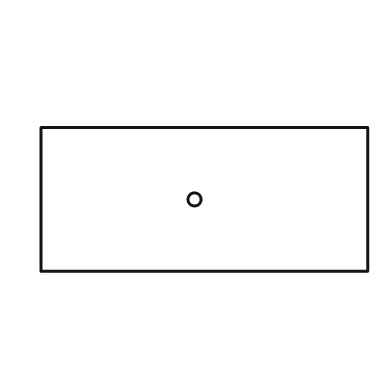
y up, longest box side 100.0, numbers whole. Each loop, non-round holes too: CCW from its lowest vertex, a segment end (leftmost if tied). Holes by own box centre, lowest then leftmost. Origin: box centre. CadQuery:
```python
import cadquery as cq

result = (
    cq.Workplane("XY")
    .moveTo(-50.0, -22.0)
    .lineTo(50.0, -22.0)
    .lineTo(50.0, 22.0)
    .lineTo(-50.0, 22.0)
    .close()
    .moveTo(-3.0, 0.0)
    .circle(2.0)
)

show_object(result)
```